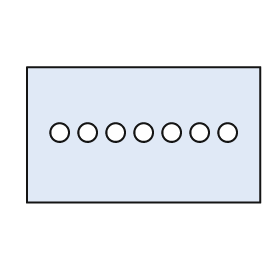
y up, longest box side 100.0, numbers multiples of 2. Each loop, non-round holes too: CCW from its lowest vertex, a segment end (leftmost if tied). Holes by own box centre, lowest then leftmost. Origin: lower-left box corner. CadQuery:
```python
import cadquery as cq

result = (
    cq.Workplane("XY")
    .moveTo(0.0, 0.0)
    .lineTo(100.0, 0.0)
    .lineTo(100.0, 58.0)
    .lineTo(0.0, 58.0)
    .close()
    .moveTo(14.0, 30.0)
    .circle(4.0)
    .moveTo(26.0, 30.0)
    .circle(4.0)
    .moveTo(38.0, 30.0)
    .circle(4.0)
    .moveTo(50.0, 30.0)
    .circle(4.0)
    .moveTo(62.0, 30.0)
    .circle(4.0)
    .moveTo(74.0, 30.0)
    .circle(4.0)
    .moveTo(86.0, 30.0)
    .circle(4.0)
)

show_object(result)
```